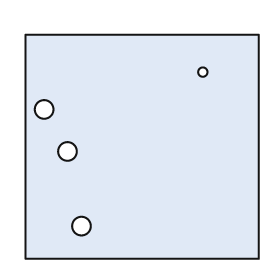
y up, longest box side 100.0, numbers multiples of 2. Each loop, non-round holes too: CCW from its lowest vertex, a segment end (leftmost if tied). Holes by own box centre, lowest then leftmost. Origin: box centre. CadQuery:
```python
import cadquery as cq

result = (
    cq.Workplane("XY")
    .moveTo(-50.0, -48.0)
    .lineTo(50.0, -48.0)
    .lineTo(50.0, 48.0)
    .lineTo(-50.0, 48.0)
    .close()
    .moveTo(-26.0, -34.0)
    .circle(4.0)
    .moveTo(-32.0, -2.0)
    .circle(4.0)
    .moveTo(-42.0, 16.0)
    .circle(4.0)
    .moveTo(26.0, 32.0)
    .circle(2.0)
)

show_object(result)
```